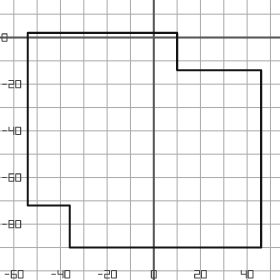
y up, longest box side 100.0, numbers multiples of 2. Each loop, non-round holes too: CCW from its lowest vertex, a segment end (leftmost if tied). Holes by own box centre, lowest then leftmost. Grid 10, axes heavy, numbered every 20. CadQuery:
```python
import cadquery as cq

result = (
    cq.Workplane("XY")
    .moveTo(-36.0, -90.0)
    .lineTo(46.0, -90.0)
    .lineTo(46.0, -14.0)
    .lineTo(10.0, -14.0)
    .lineTo(10.0, 2.0)
    .lineTo(-54.0, 2.0)
    .lineTo(-54.0, -72.0)
    .lineTo(-36.0, -72.0)
    .close()
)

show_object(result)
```